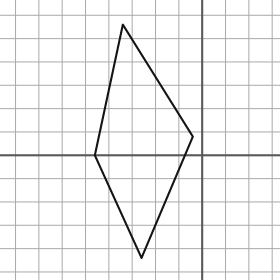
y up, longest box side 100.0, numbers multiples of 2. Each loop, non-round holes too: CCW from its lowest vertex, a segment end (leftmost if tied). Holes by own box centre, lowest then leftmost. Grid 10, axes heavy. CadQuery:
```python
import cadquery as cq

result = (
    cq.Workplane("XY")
    .moveTo(-26.0, -44.0)
    .lineTo(-4.0, 8.0)
    .lineTo(-34.0, 56.0)
    .lineTo(-46.0, 0.0)
    .close()
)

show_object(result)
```